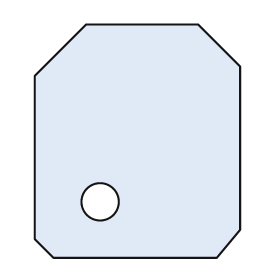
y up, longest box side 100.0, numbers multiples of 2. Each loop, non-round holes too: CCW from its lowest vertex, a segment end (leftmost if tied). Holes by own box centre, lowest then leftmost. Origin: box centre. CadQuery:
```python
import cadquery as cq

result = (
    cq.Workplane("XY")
    .moveTo(-36.0, -50.0)
    .lineTo(34.0, -50.0)
    .lineTo(44.0, -38.0)
    .lineTo(44.0, 32.0)
    .lineTo(26.0, 50.0)
    .lineTo(-22.0, 50.0)
    .lineTo(-44.0, 28.0)
    .lineTo(-44.0, -42.0)
    .close()
    .moveTo(-16.0, -26.0)
    .circle(8.0)
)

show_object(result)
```